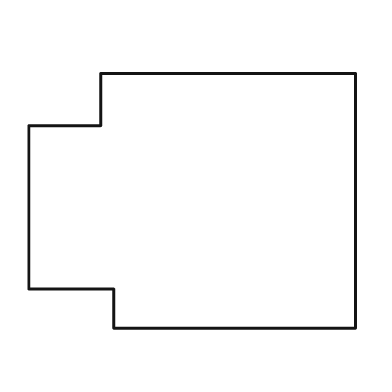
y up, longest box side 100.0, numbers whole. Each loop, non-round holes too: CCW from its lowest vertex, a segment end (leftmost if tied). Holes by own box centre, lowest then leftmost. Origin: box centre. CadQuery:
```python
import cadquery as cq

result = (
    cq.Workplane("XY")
    .moveTo(-24.0, -39.0)
    .lineTo(50.0, -39.0)
    .lineTo(50.0, 39.0)
    .lineTo(-28.0, 39.0)
    .lineTo(-28.0, 23.0)
    .lineTo(-50.0, 23.0)
    .lineTo(-50.0, -27.0)
    .lineTo(-24.0, -27.0)
    .close()
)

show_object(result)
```